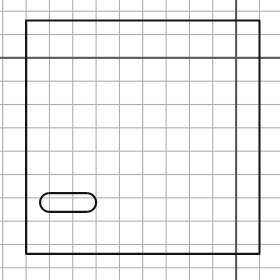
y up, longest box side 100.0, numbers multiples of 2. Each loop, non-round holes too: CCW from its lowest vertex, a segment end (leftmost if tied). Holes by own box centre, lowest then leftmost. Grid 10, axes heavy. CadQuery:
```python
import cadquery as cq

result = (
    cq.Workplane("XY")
    .moveTo(-90.0, -84.0)
    .lineTo(10.0, -84.0)
    .lineTo(10.0, 16.0)
    .lineTo(-90.0, 16.0)
    .close()
    .moveTo(-80.0, -66.0)
    .lineTo(-64.0, -66.0)
    .threePointArc((-60.0, -62.0), (-64.0, -58.0))
    .lineTo(-80.0, -58.0)
    .threePointArc((-84.0, -62.0), (-80.0, -66.0))
    .close()
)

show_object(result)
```